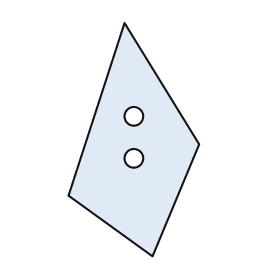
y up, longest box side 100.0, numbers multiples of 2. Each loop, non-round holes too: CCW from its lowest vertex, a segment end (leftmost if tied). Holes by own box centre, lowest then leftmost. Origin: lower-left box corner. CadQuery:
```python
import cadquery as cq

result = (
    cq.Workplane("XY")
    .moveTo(36.0, 0.0)
    .lineTo(56.0, 48.0)
    .lineTo(24.0, 100.0)
    .lineTo(0.0, 26.0)
    .close()
    .moveTo(28.0, 42.0)
    .circle(4.0)
    .moveTo(28.0, 60.0)
    .circle(4.0)
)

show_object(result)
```